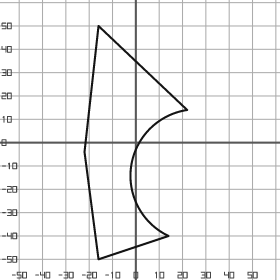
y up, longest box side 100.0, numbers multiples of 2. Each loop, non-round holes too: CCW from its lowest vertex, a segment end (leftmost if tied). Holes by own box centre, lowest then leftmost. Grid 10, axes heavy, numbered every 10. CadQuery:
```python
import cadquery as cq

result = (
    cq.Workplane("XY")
    .moveTo(-16.0, -50.0)
    .lineTo(14.0, -40.0)
    .threePointArc((-2.0, -10.0), (22.0, 14.0))
    .lineTo(-16.0, 50.0)
    .lineTo(-22.0, -4.0)
    .close()
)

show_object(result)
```